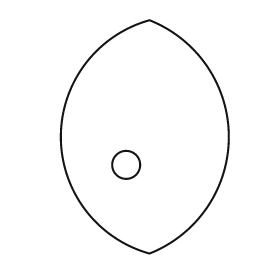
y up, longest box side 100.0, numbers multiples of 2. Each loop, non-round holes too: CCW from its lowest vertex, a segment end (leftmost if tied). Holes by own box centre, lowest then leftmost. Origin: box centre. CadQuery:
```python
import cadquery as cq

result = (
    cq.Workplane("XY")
    .moveTo(2.0, -50.0)
    .threePointArc((36.0, 0.0), (2.0, 50.0))
    .threePointArc((-36.0, 0.0), (2.0, -50.0))
    .close()
    .moveTo(-8.0, -12.0)
    .circle(6.0)
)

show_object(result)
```